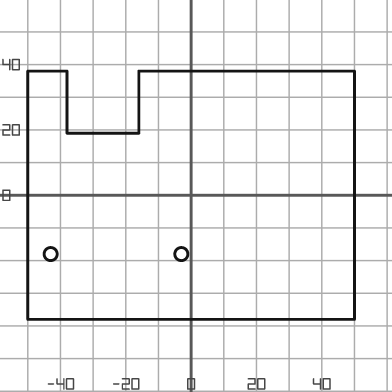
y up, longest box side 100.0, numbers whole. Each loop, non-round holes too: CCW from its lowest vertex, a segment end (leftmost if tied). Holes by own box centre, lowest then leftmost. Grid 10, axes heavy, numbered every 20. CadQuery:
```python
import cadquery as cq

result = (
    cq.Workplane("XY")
    .moveTo(-50.0, -38.0)
    .lineTo(50.0, -38.0)
    .lineTo(50.0, 38.0)
    .lineTo(-16.0, 38.0)
    .lineTo(-16.0, 19.0)
    .lineTo(-38.0, 19.0)
    .lineTo(-38.0, 38.0)
    .lineTo(-50.0, 38.0)
    .close()
    .moveTo(-43.0, -18.0)
    .circle(2.0)
    .moveTo(-3.0, -18.0)
    .circle(2.0)
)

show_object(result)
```